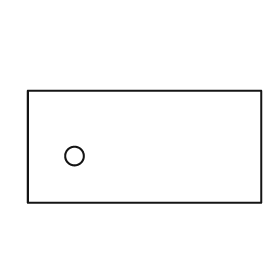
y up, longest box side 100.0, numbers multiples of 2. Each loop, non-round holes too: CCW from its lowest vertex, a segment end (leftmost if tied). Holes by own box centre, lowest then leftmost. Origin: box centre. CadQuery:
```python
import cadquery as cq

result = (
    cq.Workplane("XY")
    .moveTo(-50.0, -24.0)
    .lineTo(50.0, -24.0)
    .lineTo(50.0, 24.0)
    .lineTo(-50.0, 24.0)
    .close()
    .moveTo(-30.0, -4.0)
    .circle(4.0)
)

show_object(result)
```